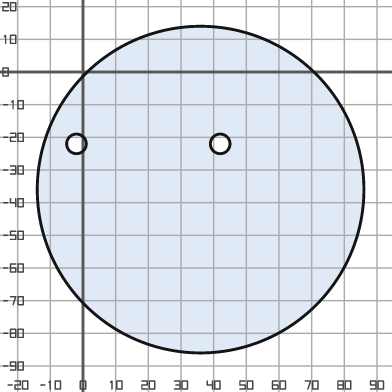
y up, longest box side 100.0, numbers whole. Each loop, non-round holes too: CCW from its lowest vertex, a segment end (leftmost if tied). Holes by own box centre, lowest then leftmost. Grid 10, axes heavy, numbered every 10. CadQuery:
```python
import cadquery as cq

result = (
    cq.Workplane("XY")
    .moveTo(36.0, -36.0)
    .circle(50.0)
    .moveTo(-2.0, -22.0)
    .circle(3.0)
    .moveTo(42.0, -22.0)
    .circle(3.0)
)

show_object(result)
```